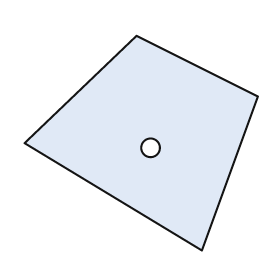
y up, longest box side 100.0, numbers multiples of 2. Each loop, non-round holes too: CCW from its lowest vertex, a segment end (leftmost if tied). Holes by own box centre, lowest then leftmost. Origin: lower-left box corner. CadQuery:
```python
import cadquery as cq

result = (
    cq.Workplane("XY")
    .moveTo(76.0, 0.0)
    .lineTo(100.0, 66.0)
    .lineTo(48.0, 92.0)
    .lineTo(0.0, 46.0)
    .close()
    .moveTo(54.0, 44.0)
    .circle(4.0)
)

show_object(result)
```